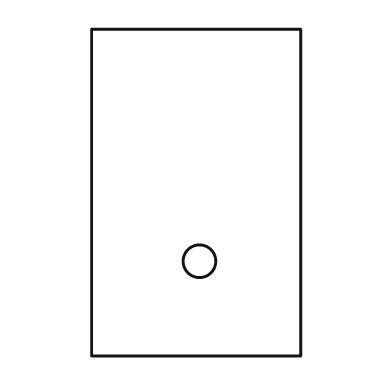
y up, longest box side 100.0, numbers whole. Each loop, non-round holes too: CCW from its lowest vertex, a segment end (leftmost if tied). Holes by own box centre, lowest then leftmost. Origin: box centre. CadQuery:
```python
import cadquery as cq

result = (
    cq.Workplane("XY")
    .moveTo(-32.0, -50.0)
    .lineTo(32.0, -50.0)
    .lineTo(32.0, 50.0)
    .lineTo(-32.0, 50.0)
    .close()
    .moveTo(1.0, -21.0)
    .circle(5.0)
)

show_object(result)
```